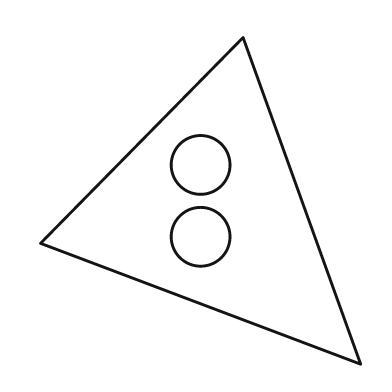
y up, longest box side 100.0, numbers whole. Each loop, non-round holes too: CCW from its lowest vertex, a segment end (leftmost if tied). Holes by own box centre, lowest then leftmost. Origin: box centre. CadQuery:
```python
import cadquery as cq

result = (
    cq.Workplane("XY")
    .moveTo(49.0, -50.0)
    .lineTo(13.0, 50.0)
    .lineTo(-49.0, -13.0)
    .close()
    .moveTo(0.0, -11.0)
    .circle(9.0)
    .moveTo(0.0, 11.0)
    .circle(9.0)
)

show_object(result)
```